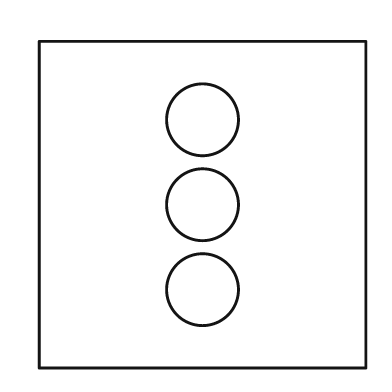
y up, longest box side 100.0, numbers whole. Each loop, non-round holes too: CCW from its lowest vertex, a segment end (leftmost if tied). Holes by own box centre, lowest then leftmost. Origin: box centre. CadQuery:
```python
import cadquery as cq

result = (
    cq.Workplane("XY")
    .moveTo(-50.0, -50.0)
    .lineTo(50.0, -50.0)
    .lineTo(50.0, 50.0)
    .lineTo(-50.0, 50.0)
    .close()
    .moveTo(0.0, -26.0)
    .circle(11.0)
    .moveTo(0.0, 0.0)
    .circle(11.0)
    .moveTo(0.0, 26.0)
    .circle(11.0)
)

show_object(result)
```